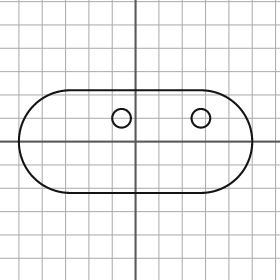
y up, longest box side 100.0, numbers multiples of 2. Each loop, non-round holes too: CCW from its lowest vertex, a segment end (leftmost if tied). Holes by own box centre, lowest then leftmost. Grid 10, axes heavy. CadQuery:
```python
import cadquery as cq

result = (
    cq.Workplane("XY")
    .moveTo(-28.0, -22.0)
    .lineTo(28.0, -22.0)
    .threePointArc((50.0, 0.0), (28.0, 22.0))
    .lineTo(-28.0, 22.0)
    .threePointArc((-50.0, 0.0), (-28.0, -22.0))
    .close()
    .moveTo(-6.0, 10.0)
    .circle(4.0)
    .moveTo(28.0, 10.0)
    .circle(4.0)
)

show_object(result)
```